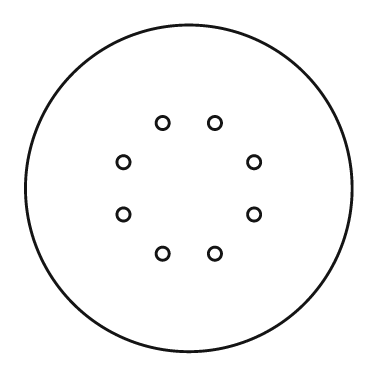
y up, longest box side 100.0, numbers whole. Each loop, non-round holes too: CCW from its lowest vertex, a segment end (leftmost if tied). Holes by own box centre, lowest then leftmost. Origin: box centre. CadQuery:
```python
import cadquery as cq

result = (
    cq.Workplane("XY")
    .moveTo(0.0, 0.0)
    .circle(50.0)
    .moveTo(-8.0, -20.0)
    .circle(2.0)
    .moveTo(8.0, -20.0)
    .circle(2.0)
    .moveTo(-20.0, -8.0)
    .circle(2.0)
    .moveTo(20.0, -8.0)
    .circle(2.0)
    .moveTo(-20.0, 8.0)
    .circle(2.0)
    .moveTo(20.0, 8.0)
    .circle(2.0)
    .moveTo(-8.0, 20.0)
    .circle(2.0)
    .moveTo(8.0, 20.0)
    .circle(2.0)
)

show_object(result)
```